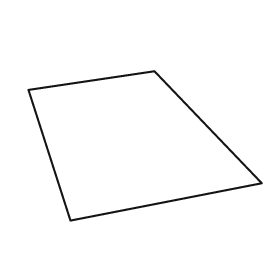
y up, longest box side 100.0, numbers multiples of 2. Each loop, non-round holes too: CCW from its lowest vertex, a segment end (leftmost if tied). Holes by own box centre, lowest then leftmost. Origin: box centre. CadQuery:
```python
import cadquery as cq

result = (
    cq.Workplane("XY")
    .moveTo(-32.0, -32.0)
    .lineTo(50.0, -16.0)
    .lineTo(4.0, 32.0)
    .lineTo(-50.0, 24.0)
    .close()
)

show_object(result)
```